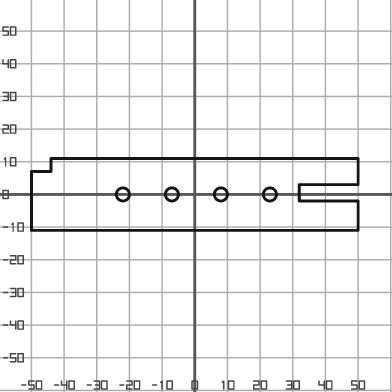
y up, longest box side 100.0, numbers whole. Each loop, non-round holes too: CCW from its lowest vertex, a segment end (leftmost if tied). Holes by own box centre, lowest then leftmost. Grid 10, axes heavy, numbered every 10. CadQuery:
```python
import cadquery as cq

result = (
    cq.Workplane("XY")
    .moveTo(-50.0, -11.0)
    .lineTo(50.0, -11.0)
    .lineTo(50.0, -2.0)
    .lineTo(32.0, -2.0)
    .lineTo(32.0, 3.0)
    .lineTo(50.0, 3.0)
    .lineTo(50.0, 11.0)
    .lineTo(-44.0, 11.0)
    .lineTo(-44.0, 7.0)
    .lineTo(-50.0, 7.0)
    .close()
    .moveTo(-22.0, 0.0)
    .circle(2.0)
    .moveTo(-7.0, 0.0)
    .circle(2.0)
    .moveTo(8.0, 0.0)
    .circle(2.0)
    .moveTo(23.0, 0.0)
    .circle(2.0)
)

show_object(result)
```